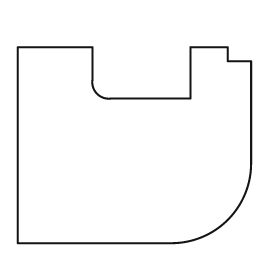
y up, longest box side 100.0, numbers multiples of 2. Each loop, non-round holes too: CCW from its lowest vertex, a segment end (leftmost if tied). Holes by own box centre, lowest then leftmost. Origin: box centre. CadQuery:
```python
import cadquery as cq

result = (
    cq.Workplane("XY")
    .moveTo(-50.0, -42.0)
    .lineTo(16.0, -42.0)
    .threePointArc((40.0, -32.0), (50.0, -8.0))
    .lineTo(50.0, 36.0)
    .lineTo(40.0, 36.0)
    .lineTo(40.0, 42.0)
    .lineTo(24.0, 42.0)
    .lineTo(24.0, 20.0)
    .lineTo(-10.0, 20.0)
    .threePointArc((-16.0, 22.0), (-18.0, 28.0))
    .lineTo(-18.0, 42.0)
    .lineTo(-50.0, 42.0)
    .close()
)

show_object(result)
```